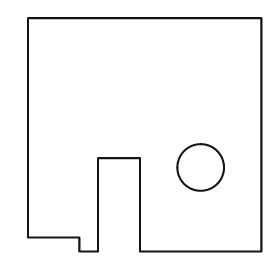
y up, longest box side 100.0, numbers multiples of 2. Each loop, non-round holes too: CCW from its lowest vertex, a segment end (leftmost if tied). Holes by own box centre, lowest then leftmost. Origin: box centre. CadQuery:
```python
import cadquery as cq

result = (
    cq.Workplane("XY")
    .moveTo(-28.0, -50.0)
    .lineTo(-20.0, -50.0)
    .lineTo(-20.0, -10.0)
    .lineTo(-2.0, -10.0)
    .lineTo(-2.0, -50.0)
    .lineTo(50.0, -50.0)
    .lineTo(50.0, 50.0)
    .lineTo(-50.0, 50.0)
    .lineTo(-50.0, -44.0)
    .lineTo(-28.0, -44.0)
    .close()
    .moveTo(24.0, -14.0)
    .circle(10.0)
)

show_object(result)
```